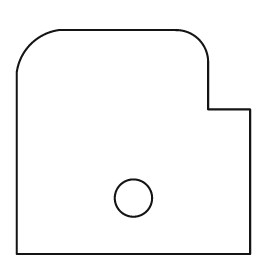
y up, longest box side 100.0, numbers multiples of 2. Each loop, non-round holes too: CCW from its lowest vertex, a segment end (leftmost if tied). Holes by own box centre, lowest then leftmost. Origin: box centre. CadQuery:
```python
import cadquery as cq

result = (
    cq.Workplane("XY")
    .moveTo(-50.0, -48.0)
    .lineTo(50.0, -48.0)
    .lineTo(50.0, 14.0)
    .lineTo(32.0, 14.0)
    .lineTo(32.0, 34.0)
    .threePointArc((28.0, 44.0), (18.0, 48.0))
    .lineTo(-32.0, 48.0)
    .threePointArc((-44.0, 42.0), (-50.0, 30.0))
    .close()
    .moveTo(0.0, -24.0)
    .circle(8.0)
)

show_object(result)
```